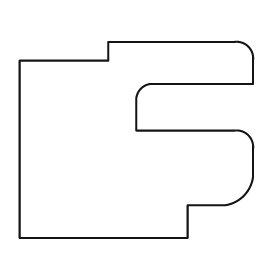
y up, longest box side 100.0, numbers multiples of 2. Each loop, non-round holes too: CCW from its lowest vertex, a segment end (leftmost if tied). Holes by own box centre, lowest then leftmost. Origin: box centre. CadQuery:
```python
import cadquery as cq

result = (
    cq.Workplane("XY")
    .moveTo(-50.0, -42.0)
    .lineTo(22.0, -42.0)
    .lineTo(22.0, -28.0)
    .lineTo(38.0, -28.0)
    .threePointArc((46.0, -24.0), (50.0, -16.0))
    .lineTo(50.0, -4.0)
    .threePointArc((48.0, 2.0), (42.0, 4.0))
    .lineTo(0.0, 4.0)
    .lineTo(0.0, 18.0)
    .threePointArc((2.0, 22.0), (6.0, 24.0))
    .lineTo(50.0, 24.0)
    .lineTo(50.0, 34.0)
    .threePointArc((48.0, 40.0), (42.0, 42.0))
    .lineTo(-12.0, 42.0)
    .lineTo(-12.0, 34.0)
    .lineTo(-50.0, 34.0)
    .close()
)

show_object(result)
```